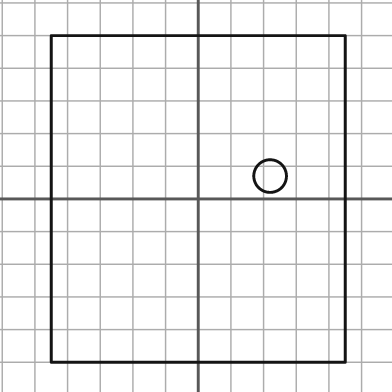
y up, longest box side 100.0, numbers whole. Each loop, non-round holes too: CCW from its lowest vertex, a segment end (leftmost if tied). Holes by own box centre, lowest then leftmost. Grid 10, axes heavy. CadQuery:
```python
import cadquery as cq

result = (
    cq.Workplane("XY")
    .moveTo(-45.0, -50.0)
    .lineTo(45.0, -50.0)
    .lineTo(45.0, 50.0)
    .lineTo(-45.0, 50.0)
    .close()
    .moveTo(22.0, 7.0)
    .circle(5.0)
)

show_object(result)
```